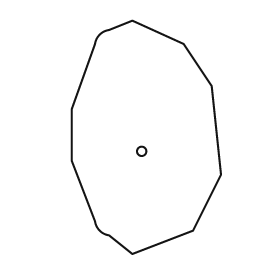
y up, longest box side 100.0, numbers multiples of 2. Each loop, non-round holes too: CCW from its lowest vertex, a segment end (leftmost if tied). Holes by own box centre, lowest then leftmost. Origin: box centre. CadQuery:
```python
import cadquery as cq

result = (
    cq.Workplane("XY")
    .moveTo(-6.0, -50.0)
    .lineTo(20.0, -40.0)
    .lineTo(32.0, -16.0)
    .lineTo(28.0, 22.0)
    .lineTo(16.0, 40.0)
    .lineTo(-6.0, 50.0)
    .lineTo(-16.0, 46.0)
    .threePointArc((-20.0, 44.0), (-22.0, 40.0))
    .lineTo(-32.0, 12.0)
    .lineTo(-32.0, -10.0)
    .lineTo(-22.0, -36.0)
    .threePointArc((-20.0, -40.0), (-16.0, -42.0))
    .close()
    .moveTo(-2.0, -6.0)
    .circle(2.0)
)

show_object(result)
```